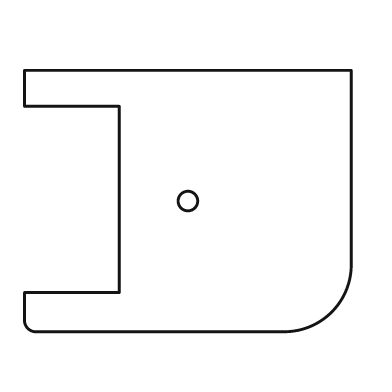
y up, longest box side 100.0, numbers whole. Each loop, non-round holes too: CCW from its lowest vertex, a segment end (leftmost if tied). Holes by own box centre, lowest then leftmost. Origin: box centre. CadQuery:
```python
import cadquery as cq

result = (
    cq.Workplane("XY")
    .moveTo(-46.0, -40.0)
    .lineTo(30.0, -40.0)
    .threePointArc((44.0, -34.0), (50.0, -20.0))
    .lineTo(50.0, 40.0)
    .lineTo(-50.0, 40.0)
    .lineTo(-50.0, 29.0)
    .lineTo(-21.0, 29.0)
    .lineTo(-21.0, -28.0)
    .lineTo(-50.0, -28.0)
    .lineTo(-50.0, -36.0)
    .threePointArc((-49.0, -39.0), (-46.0, -40.0))
    .close()
    .moveTo(0.0, 0.0)
    .circle(3.0)
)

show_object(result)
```